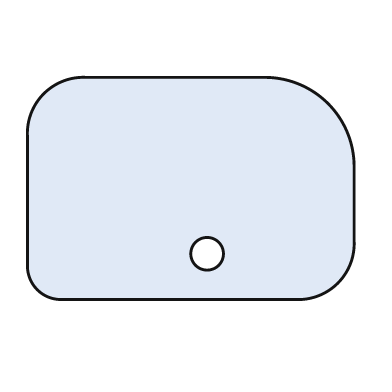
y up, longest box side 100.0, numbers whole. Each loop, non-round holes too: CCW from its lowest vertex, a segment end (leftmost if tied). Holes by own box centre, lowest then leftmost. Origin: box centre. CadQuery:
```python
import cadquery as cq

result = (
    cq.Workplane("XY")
    .moveTo(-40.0, -34.0)
    .lineTo(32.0, -34.0)
    .threePointArc((45.0, -29.0), (50.0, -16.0))
    .lineTo(50.0, 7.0)
    .threePointArc((42.0, 26.0), (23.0, 34.0))
    .lineTo(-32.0, 34.0)
    .threePointArc((-45.0, 29.0), (-50.0, 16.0))
    .lineTo(-50.0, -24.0)
    .threePointArc((-47.0, -31.0), (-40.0, -34.0))
    .close()
    .moveTo(5.0, -20.0)
    .circle(5.0)
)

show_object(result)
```